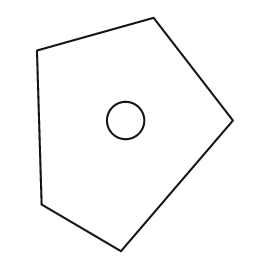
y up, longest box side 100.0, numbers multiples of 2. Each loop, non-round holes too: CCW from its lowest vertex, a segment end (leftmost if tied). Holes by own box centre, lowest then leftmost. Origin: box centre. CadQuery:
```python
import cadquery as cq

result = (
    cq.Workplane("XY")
    .moveTo(-6.0, -50.0)
    .lineTo(42.0, 6.0)
    .lineTo(8.0, 50.0)
    .lineTo(-42.0, 36.0)
    .lineTo(-40.0, -30.0)
    .close()
    .moveTo(-4.0, 6.0)
    .circle(8.0)
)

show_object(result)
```